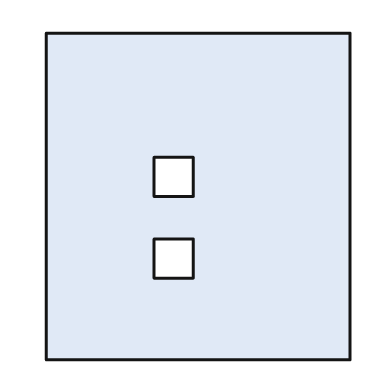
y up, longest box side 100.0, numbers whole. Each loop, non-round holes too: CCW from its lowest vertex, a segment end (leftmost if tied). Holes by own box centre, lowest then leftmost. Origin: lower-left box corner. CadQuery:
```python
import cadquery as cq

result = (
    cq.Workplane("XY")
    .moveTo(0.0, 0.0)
    .lineTo(93.0, 0.0)
    .lineTo(93.0, 100.0)
    .lineTo(0.0, 100.0)
    .close()
    .moveTo(33.0, 25.0)
    .lineTo(45.0, 25.0)
    .lineTo(45.0, 37.0)
    .lineTo(33.0, 37.0)
    .close()
    .moveTo(33.0, 50.0)
    .lineTo(45.0, 50.0)
    .lineTo(45.0, 62.0)
    .lineTo(33.0, 62.0)
    .close()
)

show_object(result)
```